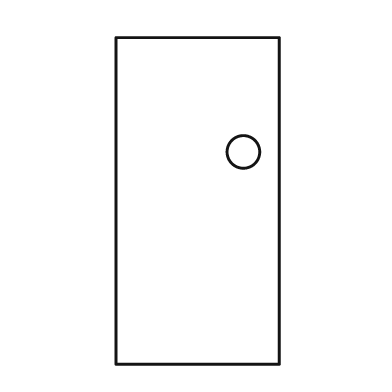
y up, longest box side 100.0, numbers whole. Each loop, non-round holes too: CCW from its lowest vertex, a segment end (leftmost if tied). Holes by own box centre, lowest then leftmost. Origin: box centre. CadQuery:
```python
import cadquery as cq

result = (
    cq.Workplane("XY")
    .moveTo(-25.0, -50.0)
    .lineTo(25.0, -50.0)
    .lineTo(25.0, 50.0)
    .lineTo(-25.0, 50.0)
    .close()
    .moveTo(14.0, 15.0)
    .circle(5.0)
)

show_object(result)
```